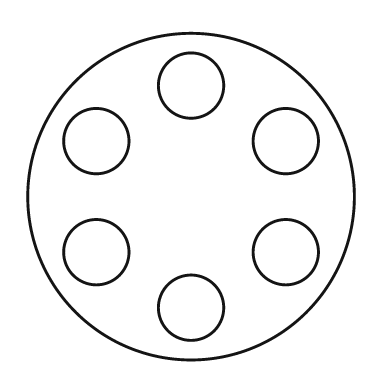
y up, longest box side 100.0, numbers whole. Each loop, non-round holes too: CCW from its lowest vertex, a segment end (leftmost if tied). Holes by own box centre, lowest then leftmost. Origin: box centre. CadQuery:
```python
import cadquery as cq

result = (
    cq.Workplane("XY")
    .moveTo(0.0, 0.0)
    .circle(50.0)
    .moveTo(0.0, -34.0)
    .circle(10.0)
    .moveTo(-29.0, -17.0)
    .circle(10.0)
    .moveTo(29.0, -17.0)
    .circle(10.0)
    .moveTo(-29.0, 17.0)
    .circle(10.0)
    .moveTo(29.0, 17.0)
    .circle(10.0)
    .moveTo(0.0, 34.0)
    .circle(10.0)
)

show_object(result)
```